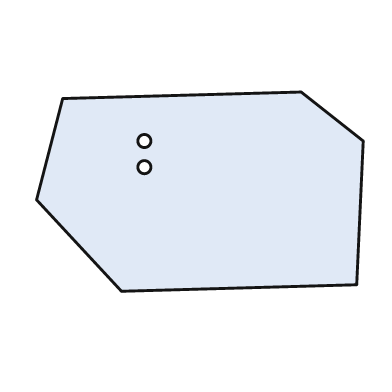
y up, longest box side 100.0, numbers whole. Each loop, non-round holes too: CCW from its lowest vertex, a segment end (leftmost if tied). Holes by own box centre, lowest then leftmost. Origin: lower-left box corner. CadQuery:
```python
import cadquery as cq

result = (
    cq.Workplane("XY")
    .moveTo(26.0, 0.0)
    .lineTo(98.0, 2.0)
    .lineTo(100.0, 46.0)
    .lineTo(81.0, 61.0)
    .lineTo(8.0, 59.0)
    .lineTo(0.0, 28.0)
    .close()
    .moveTo(33.0, 38.0)
    .circle(2.0)
    .moveTo(33.0, 46.0)
    .circle(2.0)
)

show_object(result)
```